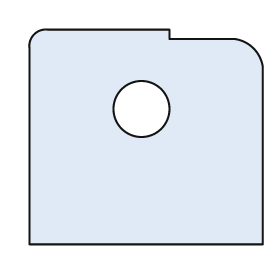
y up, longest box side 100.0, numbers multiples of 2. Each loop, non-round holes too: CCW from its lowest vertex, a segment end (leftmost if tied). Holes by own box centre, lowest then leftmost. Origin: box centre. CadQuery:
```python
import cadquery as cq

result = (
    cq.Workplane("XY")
    .moveTo(-50.0, -46.0)
    .lineTo(50.0, -46.0)
    .lineTo(50.0, 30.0)
    .threePointArc((46.0, 38.0), (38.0, 42.0))
    .lineTo(10.0, 42.0)
    .lineTo(10.0, 46.0)
    .lineTo(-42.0, 46.0)
    .threePointArc((-48.0, 44.0), (-50.0, 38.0))
    .close()
    .moveTo(-2.0, 12.0)
    .circle(12.0)
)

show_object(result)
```